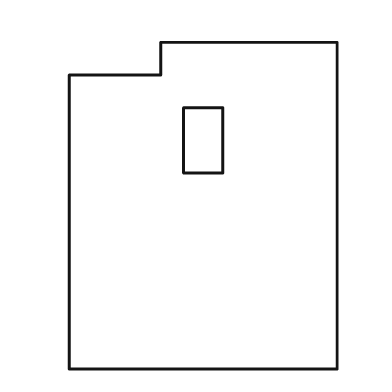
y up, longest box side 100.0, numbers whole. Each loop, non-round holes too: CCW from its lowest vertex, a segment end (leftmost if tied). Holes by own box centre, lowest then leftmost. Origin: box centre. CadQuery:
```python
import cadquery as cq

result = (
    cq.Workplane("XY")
    .moveTo(-41.0, -50.0)
    .lineTo(41.0, -50.0)
    .lineTo(41.0, 50.0)
    .lineTo(-13.0, 50.0)
    .lineTo(-13.0, 40.0)
    .lineTo(-41.0, 40.0)
    .close()
    .moveTo(-6.0, 10.0)
    .lineTo(6.0, 10.0)
    .lineTo(6.0, 30.0)
    .lineTo(-6.0, 30.0)
    .close()
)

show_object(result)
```